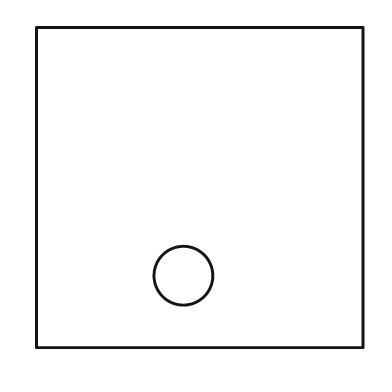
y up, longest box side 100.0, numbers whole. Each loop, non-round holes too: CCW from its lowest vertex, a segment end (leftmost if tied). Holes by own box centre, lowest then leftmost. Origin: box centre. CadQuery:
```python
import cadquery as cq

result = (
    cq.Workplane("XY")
    .moveTo(-50.0, -49.0)
    .lineTo(50.0, -49.0)
    .lineTo(50.0, 49.0)
    .lineTo(-50.0, 49.0)
    .close()
    .moveTo(-5.0, -27.0)
    .circle(9.0)
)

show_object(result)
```